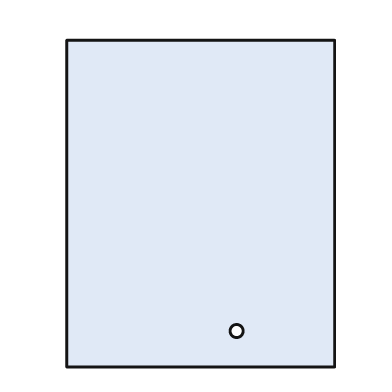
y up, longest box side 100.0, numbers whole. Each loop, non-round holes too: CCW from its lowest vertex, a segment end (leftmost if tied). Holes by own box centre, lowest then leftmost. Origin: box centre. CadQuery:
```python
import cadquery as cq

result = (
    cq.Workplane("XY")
    .moveTo(-41.0, -50.0)
    .lineTo(41.0, -50.0)
    .lineTo(41.0, 50.0)
    .lineTo(-41.0, 50.0)
    .close()
    .moveTo(11.0, -39.0)
    .circle(2.0)
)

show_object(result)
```